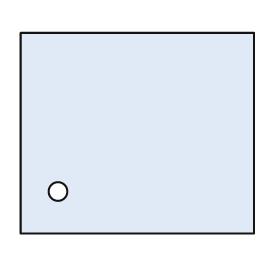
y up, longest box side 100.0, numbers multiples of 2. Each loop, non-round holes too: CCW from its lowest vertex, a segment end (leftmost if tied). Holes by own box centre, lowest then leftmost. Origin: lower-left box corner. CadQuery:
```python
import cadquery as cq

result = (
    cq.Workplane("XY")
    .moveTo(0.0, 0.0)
    .lineTo(100.0, 0.0)
    .lineTo(100.0, 86.0)
    .lineTo(0.0, 86.0)
    .close()
    .moveTo(16.0, 18.0)
    .circle(4.0)
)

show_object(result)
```